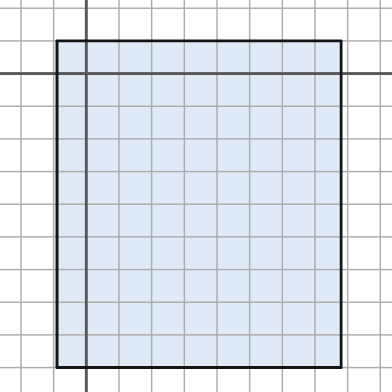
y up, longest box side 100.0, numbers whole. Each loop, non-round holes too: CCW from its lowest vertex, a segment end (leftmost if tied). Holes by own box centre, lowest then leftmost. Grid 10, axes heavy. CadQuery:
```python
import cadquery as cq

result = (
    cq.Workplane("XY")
    .moveTo(-9.0, -90.0)
    .lineTo(78.0, -90.0)
    .lineTo(78.0, 10.0)
    .lineTo(-9.0, 10.0)
    .close()
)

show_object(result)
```